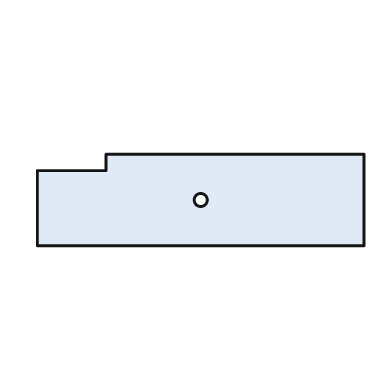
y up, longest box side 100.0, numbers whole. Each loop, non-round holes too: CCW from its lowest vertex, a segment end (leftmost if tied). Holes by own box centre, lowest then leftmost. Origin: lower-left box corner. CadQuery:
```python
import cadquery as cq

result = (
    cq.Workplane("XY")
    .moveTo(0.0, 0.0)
    .lineTo(100.0, 0.0)
    .lineTo(100.0, 28.0)
    .lineTo(21.0, 28.0)
    .lineTo(21.0, 23.0)
    .lineTo(0.0, 23.0)
    .close()
    .moveTo(50.0, 14.0)
    .circle(2.0)
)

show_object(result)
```